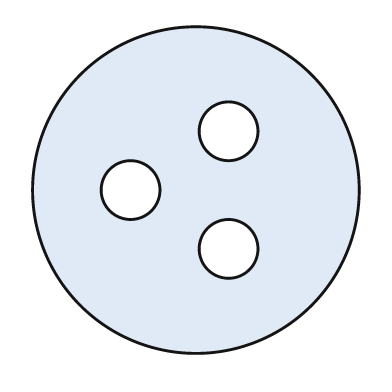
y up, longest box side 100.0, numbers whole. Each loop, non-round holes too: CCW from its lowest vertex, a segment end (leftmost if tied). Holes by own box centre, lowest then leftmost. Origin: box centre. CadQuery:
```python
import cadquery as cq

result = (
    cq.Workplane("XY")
    .moveTo(0.0, 0.0)
    .circle(50.0)
    .moveTo(10.0, -18.0)
    .circle(9.0)
    .moveTo(-20.0, 0.0)
    .circle(9.0)
    .moveTo(10.0, 18.0)
    .circle(9.0)
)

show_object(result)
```